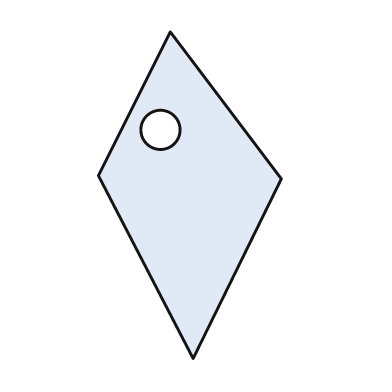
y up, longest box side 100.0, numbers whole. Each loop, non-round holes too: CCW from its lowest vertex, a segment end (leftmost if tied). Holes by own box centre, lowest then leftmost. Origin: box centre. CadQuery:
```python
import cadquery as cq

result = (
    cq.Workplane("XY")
    .moveTo(1.0, -50.0)
    .lineTo(28.0, 5.0)
    .lineTo(-6.0, 50.0)
    .lineTo(-28.0, 6.0)
    .close()
    .moveTo(-9.0, 20.0)
    .circle(6.0)
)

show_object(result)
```